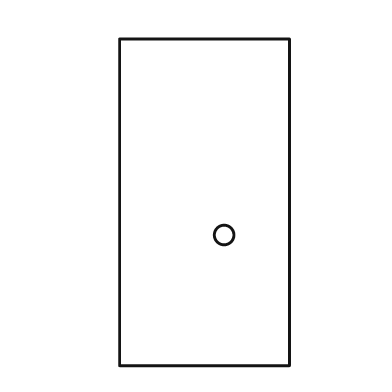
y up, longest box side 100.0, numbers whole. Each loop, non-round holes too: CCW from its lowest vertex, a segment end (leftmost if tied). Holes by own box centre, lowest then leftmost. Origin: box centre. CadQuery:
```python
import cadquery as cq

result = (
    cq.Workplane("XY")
    .moveTo(-26.0, -50.0)
    .lineTo(26.0, -50.0)
    .lineTo(26.0, 50.0)
    .lineTo(-26.0, 50.0)
    .close()
    .moveTo(6.0, -10.0)
    .circle(3.0)
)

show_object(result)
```